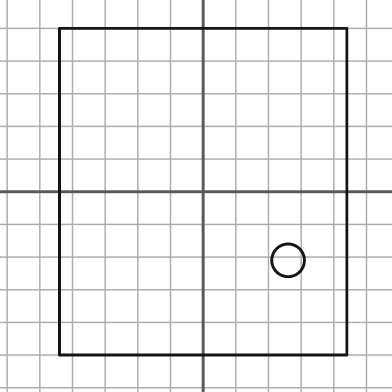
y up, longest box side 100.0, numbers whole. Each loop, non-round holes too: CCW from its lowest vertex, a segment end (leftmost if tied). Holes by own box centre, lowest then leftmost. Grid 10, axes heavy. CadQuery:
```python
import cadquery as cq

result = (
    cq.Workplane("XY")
    .moveTo(-44.0, -50.0)
    .lineTo(44.0, -50.0)
    .lineTo(44.0, 50.0)
    .lineTo(-44.0, 50.0)
    .close()
    .moveTo(26.0, -21.0)
    .circle(5.0)
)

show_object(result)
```